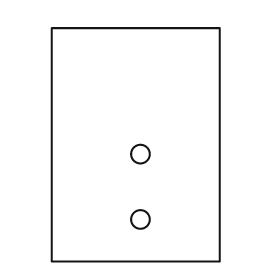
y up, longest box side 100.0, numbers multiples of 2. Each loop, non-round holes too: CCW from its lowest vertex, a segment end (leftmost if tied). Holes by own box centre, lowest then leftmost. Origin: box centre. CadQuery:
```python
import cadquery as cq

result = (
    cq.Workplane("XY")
    .moveTo(-36.0, -50.0)
    .lineTo(36.0, -50.0)
    .lineTo(36.0, 50.0)
    .lineTo(-36.0, 50.0)
    .close()
    .moveTo(2.0, -32.0)
    .circle(4.0)
    .moveTo(2.0, -4.0)
    .circle(4.0)
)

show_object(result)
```